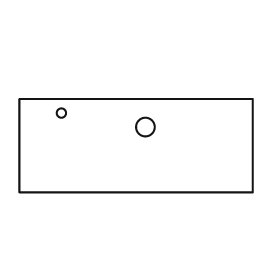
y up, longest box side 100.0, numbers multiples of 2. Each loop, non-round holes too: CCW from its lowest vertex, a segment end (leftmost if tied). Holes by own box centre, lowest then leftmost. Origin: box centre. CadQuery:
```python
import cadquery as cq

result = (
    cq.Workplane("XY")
    .moveTo(-50.0, -20.0)
    .lineTo(50.0, -20.0)
    .lineTo(50.0, 20.0)
    .lineTo(-50.0, 20.0)
    .close()
    .moveTo(4.0, 8.0)
    .circle(4.0)
    .moveTo(-32.0, 14.0)
    .circle(2.0)
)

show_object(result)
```